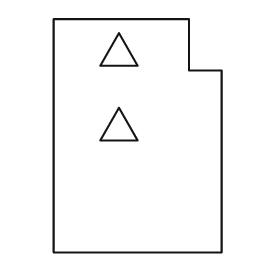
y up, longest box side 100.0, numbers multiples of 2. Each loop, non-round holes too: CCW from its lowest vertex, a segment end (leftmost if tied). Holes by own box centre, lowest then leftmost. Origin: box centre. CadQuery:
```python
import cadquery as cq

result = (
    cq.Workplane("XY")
    .moveTo(-36.0, -50.0)
    .lineTo(36.0, -50.0)
    .lineTo(36.0, 28.0)
    .lineTo(22.0, 28.0)
    .lineTo(22.0, 50.0)
    .lineTo(-36.0, 50.0)
    .close()
    .moveTo(-16.0, -2.0)
    .lineTo(0.0, -2.0)
    .lineTo(-8.0, 12.0)
    .close()
    .moveTo(-16.0, 30.0)
    .lineTo(0.0, 30.0)
    .lineTo(-8.0, 44.0)
    .close()
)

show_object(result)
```